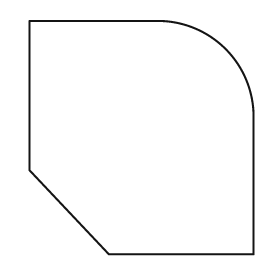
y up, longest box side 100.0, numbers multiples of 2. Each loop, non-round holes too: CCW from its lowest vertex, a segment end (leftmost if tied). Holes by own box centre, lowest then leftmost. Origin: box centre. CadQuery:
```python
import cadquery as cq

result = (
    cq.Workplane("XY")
    .moveTo(-14.0, -50.0)
    .lineTo(48.0, -50.0)
    .lineTo(48.0, 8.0)
    .threePointArc((36.0, 38.0), (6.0, 50.0))
    .lineTo(-48.0, 50.0)
    .lineTo(-48.0, -14.0)
    .close()
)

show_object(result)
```